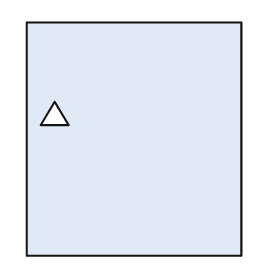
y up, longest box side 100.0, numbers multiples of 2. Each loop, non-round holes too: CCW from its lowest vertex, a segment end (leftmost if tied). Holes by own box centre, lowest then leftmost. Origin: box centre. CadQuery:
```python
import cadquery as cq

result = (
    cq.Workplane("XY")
    .moveTo(-46.0, -50.0)
    .lineTo(46.0, -50.0)
    .lineTo(46.0, 50.0)
    .lineTo(-46.0, 50.0)
    .close()
    .moveTo(-40.0, 6.0)
    .lineTo(-28.0, 6.0)
    .lineTo(-34.0, 16.0)
    .close()
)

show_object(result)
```